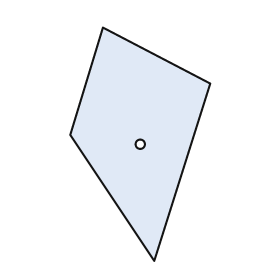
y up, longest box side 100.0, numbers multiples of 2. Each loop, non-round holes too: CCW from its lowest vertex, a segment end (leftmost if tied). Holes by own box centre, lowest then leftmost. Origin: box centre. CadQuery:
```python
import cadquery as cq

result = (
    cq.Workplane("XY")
    .moveTo(6.0, -50.0)
    .lineTo(30.0, 26.0)
    .lineTo(-16.0, 50.0)
    .lineTo(-30.0, 4.0)
    .close()
    .moveTo(0.0, 0.0)
    .circle(2.0)
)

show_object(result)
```